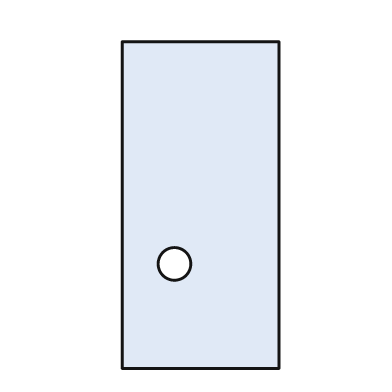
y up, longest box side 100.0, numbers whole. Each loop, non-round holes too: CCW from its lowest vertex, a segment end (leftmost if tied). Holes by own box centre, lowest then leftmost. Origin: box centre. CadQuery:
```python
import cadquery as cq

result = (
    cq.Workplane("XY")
    .moveTo(-24.0, -50.0)
    .lineTo(24.0, -50.0)
    .lineTo(24.0, 50.0)
    .lineTo(-24.0, 50.0)
    .close()
    .moveTo(-8.0, -18.0)
    .circle(5.0)
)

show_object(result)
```